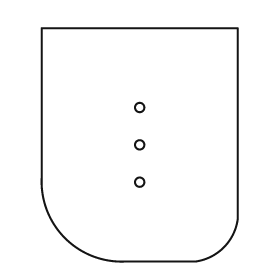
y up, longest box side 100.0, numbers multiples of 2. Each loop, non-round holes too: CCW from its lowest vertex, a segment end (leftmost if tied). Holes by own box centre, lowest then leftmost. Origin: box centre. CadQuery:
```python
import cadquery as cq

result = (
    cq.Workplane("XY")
    .moveTo(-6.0, -50.0)
    .lineTo(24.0, -50.0)
    .threePointArc((36.0, -44.0), (42.0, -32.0))
    .lineTo(42.0, 50.0)
    .lineTo(-42.0, 50.0)
    .lineTo(-42.0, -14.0)
    .threePointArc((-32.0, -40.0), (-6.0, -50.0))
    .close()
    .moveTo(0.0, -16.0)
    .circle(2.0)
    .moveTo(0.0, 0.0)
    .circle(2.0)
    .moveTo(0.0, 16.0)
    .circle(2.0)
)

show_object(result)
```